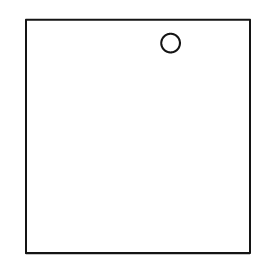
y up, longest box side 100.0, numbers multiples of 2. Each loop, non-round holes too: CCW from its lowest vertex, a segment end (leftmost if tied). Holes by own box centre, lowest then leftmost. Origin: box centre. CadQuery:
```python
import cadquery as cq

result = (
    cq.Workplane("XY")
    .moveTo(-48.0, -50.0)
    .lineTo(48.0, -50.0)
    .lineTo(48.0, 50.0)
    .lineTo(-48.0, 50.0)
    .close()
    .moveTo(14.0, 40.0)
    .circle(4.0)
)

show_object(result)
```